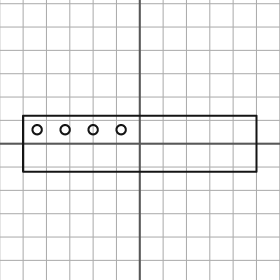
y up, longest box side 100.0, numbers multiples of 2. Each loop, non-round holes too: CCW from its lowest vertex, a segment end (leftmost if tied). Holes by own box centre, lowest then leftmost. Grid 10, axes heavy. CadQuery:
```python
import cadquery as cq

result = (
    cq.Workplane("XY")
    .moveTo(-50.0, -12.0)
    .lineTo(50.0, -12.0)
    .lineTo(50.0, 12.0)
    .lineTo(-50.0, 12.0)
    .close()
    .moveTo(-44.0, 6.0)
    .circle(2.0)
    .moveTo(-32.0, 6.0)
    .circle(2.0)
    .moveTo(-20.0, 6.0)
    .circle(2.0)
    .moveTo(-8.0, 6.0)
    .circle(2.0)
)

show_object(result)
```